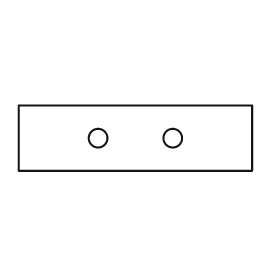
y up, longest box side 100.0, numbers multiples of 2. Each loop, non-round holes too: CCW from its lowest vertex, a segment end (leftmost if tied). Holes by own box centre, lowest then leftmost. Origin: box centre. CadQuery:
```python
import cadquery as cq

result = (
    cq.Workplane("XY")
    .moveTo(-50.0, -14.0)
    .lineTo(50.0, -14.0)
    .lineTo(50.0, 14.0)
    .lineTo(-50.0, 14.0)
    .close()
    .moveTo(-16.0, 0.0)
    .circle(4.0)
    .moveTo(16.0, 0.0)
    .circle(4.0)
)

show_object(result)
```